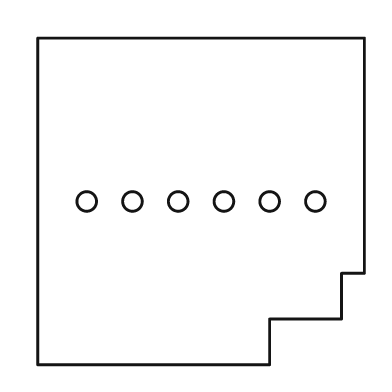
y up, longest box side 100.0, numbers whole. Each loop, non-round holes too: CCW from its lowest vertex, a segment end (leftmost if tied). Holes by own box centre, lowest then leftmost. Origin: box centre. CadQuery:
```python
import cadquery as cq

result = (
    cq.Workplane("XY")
    .moveTo(-50.0, -50.0)
    .lineTo(21.0, -50.0)
    .lineTo(21.0, -36.0)
    .lineTo(43.0, -36.0)
    .lineTo(43.0, -22.0)
    .lineTo(50.0, -22.0)
    .lineTo(50.0, 50.0)
    .lineTo(-50.0, 50.0)
    .close()
    .moveTo(-35.0, 0.0)
    .circle(3.0)
    .moveTo(-21.0, 0.0)
    .circle(3.0)
    .moveTo(-7.0, 0.0)
    .circle(3.0)
    .moveTo(7.0, 0.0)
    .circle(3.0)
    .moveTo(21.0, 0.0)
    .circle(3.0)
    .moveTo(35.0, 0.0)
    .circle(3.0)
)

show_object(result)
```